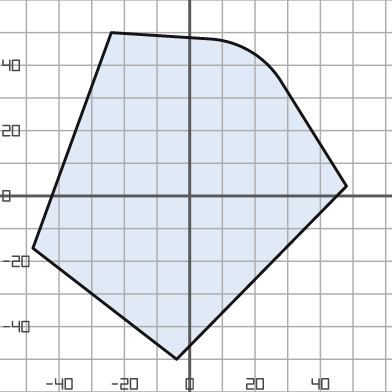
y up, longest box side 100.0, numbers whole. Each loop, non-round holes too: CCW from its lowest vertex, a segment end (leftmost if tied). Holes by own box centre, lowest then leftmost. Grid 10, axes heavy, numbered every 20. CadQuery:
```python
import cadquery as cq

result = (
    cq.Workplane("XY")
    .moveTo(-4.0, -50.0)
    .lineTo(48.0, 3.0)
    .lineTo(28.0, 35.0)
    .threePointArc((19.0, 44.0), (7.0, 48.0))
    .lineTo(-24.0, 50.0)
    .lineTo(-48.0, -16.0)
    .close()
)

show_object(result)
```